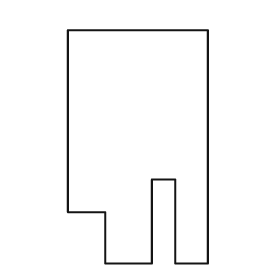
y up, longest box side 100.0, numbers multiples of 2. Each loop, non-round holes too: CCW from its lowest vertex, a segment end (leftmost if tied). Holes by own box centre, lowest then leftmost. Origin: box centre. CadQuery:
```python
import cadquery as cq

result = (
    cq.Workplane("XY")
    .moveTo(-14.0, -50.0)
    .lineTo(6.0, -50.0)
    .lineTo(6.0, -14.0)
    .lineTo(16.0, -14.0)
    .lineTo(16.0, -50.0)
    .lineTo(30.0, -50.0)
    .lineTo(30.0, 50.0)
    .lineTo(-30.0, 50.0)
    .lineTo(-30.0, -28.0)
    .lineTo(-14.0, -28.0)
    .close()
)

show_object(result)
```